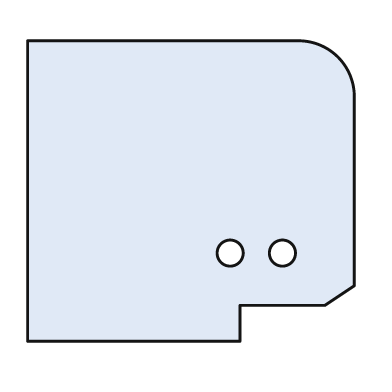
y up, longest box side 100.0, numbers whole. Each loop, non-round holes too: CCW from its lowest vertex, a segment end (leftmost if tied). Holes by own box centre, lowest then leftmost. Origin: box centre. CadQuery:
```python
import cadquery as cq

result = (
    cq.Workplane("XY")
    .moveTo(-50.0, -46.0)
    .lineTo(15.0, -46.0)
    .lineTo(15.0, -35.0)
    .lineTo(41.0, -35.0)
    .lineTo(50.0, -29.0)
    .lineTo(50.0, 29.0)
    .threePointArc((45.0, 41.0), (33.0, 46.0))
    .lineTo(-50.0, 46.0)
    .close()
    .moveTo(12.0, -19.0)
    .circle(4.0)
    .moveTo(28.0, -19.0)
    .circle(4.0)
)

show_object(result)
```